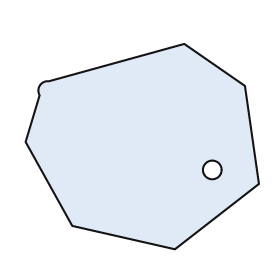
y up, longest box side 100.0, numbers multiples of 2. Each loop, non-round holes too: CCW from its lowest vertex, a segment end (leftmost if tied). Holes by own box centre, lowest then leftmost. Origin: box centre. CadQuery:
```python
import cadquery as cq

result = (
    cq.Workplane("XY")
    .moveTo(14.0, -44.0)
    .lineTo(50.0, -16.0)
    .lineTo(44.0, 26.0)
    .lineTo(18.0, 44.0)
    .lineTo(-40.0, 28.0)
    .threePointArc((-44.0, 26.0), (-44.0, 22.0))
    .lineTo(-50.0, 2.0)
    .lineTo(-30.0, -34.0)
    .close()
    .moveTo(30.0, -10.0)
    .circle(4.0)
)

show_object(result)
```